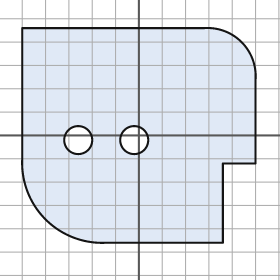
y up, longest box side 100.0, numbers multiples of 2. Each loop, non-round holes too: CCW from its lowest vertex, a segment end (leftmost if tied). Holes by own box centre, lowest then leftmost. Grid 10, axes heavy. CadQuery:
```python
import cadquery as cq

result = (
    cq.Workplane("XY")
    .moveTo(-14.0, -46.0)
    .lineTo(36.0, -46.0)
    .lineTo(36.0, -12.0)
    .lineTo(50.0, -12.0)
    .lineTo(50.0, 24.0)
    .threePointArc((44.0, 40.0), (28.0, 46.0))
    .lineTo(-50.0, 46.0)
    .lineTo(-50.0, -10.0)
    .threePointArc((-40.0, -36.0), (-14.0, -46.0))
    .close()
    .moveTo(-26.0, -2.0)
    .circle(6.0)
    .moveTo(-2.0, -2.0)
    .circle(6.0)
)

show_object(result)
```